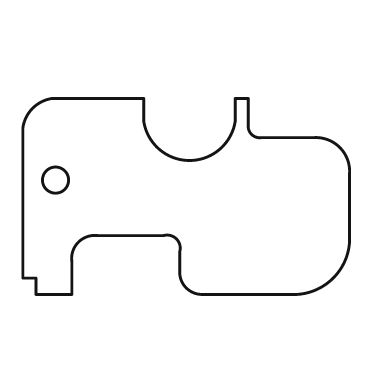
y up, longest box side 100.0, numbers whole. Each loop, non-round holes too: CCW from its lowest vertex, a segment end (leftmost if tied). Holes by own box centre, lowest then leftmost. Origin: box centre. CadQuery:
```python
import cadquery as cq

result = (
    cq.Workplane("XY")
    .moveTo(-46.0, -30.0)
    .lineTo(-35.0, -30.0)
    .lineTo(-35.0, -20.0)
    .threePointArc((-33.0, -14.0), (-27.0, -12.0))
    .lineTo(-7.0, -12.0)
    .threePointArc((-3.0, -13.0), (-2.0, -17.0))
    .lineTo(-2.0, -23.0)
    .threePointArc((0.0, -28.0), (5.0, -30.0))
    .lineTo(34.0, -30.0)
    .threePointArc((45.0, -25.0), (50.0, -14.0))
    .lineTo(50.0, 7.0)
    .threePointArc((47.0, 15.0), (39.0, 18.0))
    .lineTo(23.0, 18.0)
    .threePointArc((20.0, 19.0), (19.0, 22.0))
    .lineTo(19.0, 30.0)
    .lineTo(15.0, 30.0)
    .lineTo(15.0, 23.0)
    .threePointArc((1.0, 11.0), (-13.0, 23.0))
    .lineTo(-13.0, 30.0)
    .lineTo(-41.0, 30.0)
    .threePointArc((-47.0, 27.0), (-50.0, 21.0))
    .lineTo(-50.0, -25.0)
    .lineTo(-46.0, -25.0)
    .close()
    .moveTo(-40.0, 5.0)
    .circle(4.0)
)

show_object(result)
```